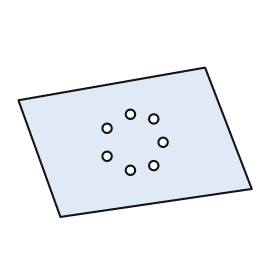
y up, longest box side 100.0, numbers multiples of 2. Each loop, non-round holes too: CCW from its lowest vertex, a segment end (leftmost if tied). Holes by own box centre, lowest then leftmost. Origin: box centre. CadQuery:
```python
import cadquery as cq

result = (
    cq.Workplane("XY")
    .moveTo(-32.0, -32.0)
    .lineTo(50.0, -20.0)
    .lineTo(30.0, 32.0)
    .lineTo(-50.0, 18.0)
    .close()
    .moveTo(-2.0, -12.0)
    .circle(2.0)
    .moveTo(8.0, -10.0)
    .circle(2.0)
    .moveTo(-12.0, -6.0)
    .circle(2.0)
    .moveTo(12.0, 0.0)
    .circle(2.0)
    .moveTo(-12.0, 6.0)
    .circle(2.0)
    .moveTo(8.0, 10.0)
    .circle(2.0)
    .moveTo(-2.0, 12.0)
    .circle(2.0)
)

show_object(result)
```